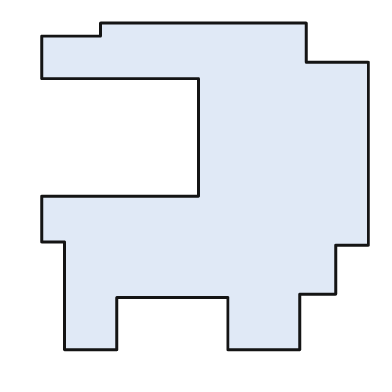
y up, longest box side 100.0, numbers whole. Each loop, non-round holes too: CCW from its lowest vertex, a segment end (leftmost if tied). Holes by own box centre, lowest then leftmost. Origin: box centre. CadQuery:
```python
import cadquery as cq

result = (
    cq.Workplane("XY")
    .moveTo(-43.0, -50.0)
    .lineTo(-27.0, -50.0)
    .lineTo(-27.0, -34.0)
    .lineTo(7.0, -34.0)
    .lineTo(7.0, -50.0)
    .lineTo(29.0, -50.0)
    .lineTo(29.0, -33.0)
    .lineTo(40.0, -33.0)
    .lineTo(40.0, -18.0)
    .lineTo(50.0, -18.0)
    .lineTo(50.0, 38.0)
    .lineTo(31.0, 38.0)
    .lineTo(31.0, 50.0)
    .lineTo(-32.0, 50.0)
    .lineTo(-32.0, 46.0)
    .lineTo(-50.0, 46.0)
    .lineTo(-50.0, 33.0)
    .lineTo(-2.0, 33.0)
    .lineTo(-2.0, -3.0)
    .lineTo(-50.0, -3.0)
    .lineTo(-50.0, -17.0)
    .lineTo(-43.0, -17.0)
    .close()
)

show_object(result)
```